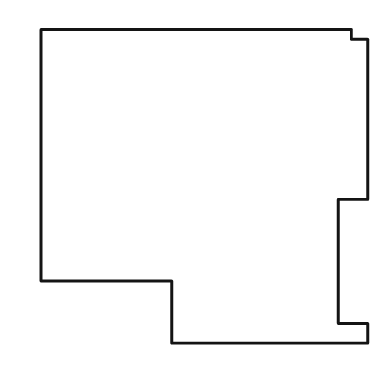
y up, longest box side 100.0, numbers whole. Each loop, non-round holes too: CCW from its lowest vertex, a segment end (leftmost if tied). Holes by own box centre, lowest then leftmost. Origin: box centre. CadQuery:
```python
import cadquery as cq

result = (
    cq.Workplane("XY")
    .moveTo(-10.0, -48.0)
    .lineTo(50.0, -48.0)
    .lineTo(50.0, -42.0)
    .lineTo(41.0, -42.0)
    .lineTo(41.0, -4.0)
    .lineTo(50.0, -4.0)
    .lineTo(50.0, 45.0)
    .lineTo(45.0, 45.0)
    .lineTo(45.0, 48.0)
    .lineTo(-50.0, 48.0)
    .lineTo(-50.0, -29.0)
    .lineTo(-10.0, -29.0)
    .close()
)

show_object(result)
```